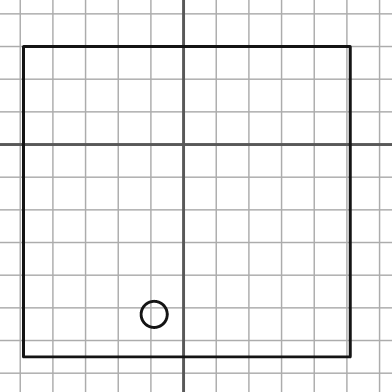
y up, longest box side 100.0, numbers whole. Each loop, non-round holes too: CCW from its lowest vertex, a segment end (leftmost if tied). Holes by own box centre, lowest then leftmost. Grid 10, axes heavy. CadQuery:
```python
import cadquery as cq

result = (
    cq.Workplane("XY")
    .moveTo(-49.0, -65.0)
    .lineTo(51.0, -65.0)
    .lineTo(51.0, 30.0)
    .lineTo(-49.0, 30.0)
    .close()
    .moveTo(-9.0, -52.0)
    .circle(4.0)
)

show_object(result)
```